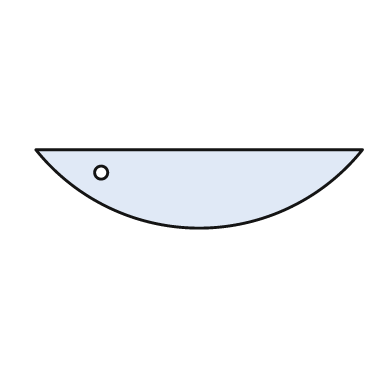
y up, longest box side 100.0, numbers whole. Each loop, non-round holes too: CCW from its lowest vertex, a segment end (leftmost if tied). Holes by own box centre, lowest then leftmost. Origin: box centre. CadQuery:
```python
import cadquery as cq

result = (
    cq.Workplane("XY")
    .moveTo(-50.0, 12.0)
    .threePointArc((0.0, -12.0), (50.0, 12.0))
    .close()
    .moveTo(-30.0, 5.0)
    .circle(2.0)
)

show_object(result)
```